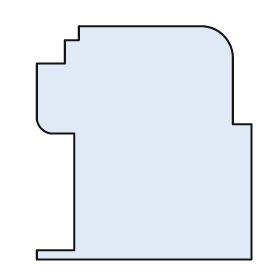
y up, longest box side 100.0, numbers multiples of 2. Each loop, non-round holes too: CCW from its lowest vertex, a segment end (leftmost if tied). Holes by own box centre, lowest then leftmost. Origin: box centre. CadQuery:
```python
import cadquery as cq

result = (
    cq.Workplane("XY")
    .moveTo(-46.0, -50.0)
    .lineTo(46.0, -50.0)
    .lineTo(46.0, 8.0)
    .lineTo(38.0, 8.0)
    .lineTo(38.0, 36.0)
    .threePointArc((34.0, 46.0), (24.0, 50.0))
    .lineTo(-28.0, 50.0)
    .lineTo(-28.0, 44.0)
    .lineTo(-34.0, 44.0)
    .lineTo(-34.0, 34.0)
    .lineTo(-46.0, 34.0)
    .lineTo(-46.0, 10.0)
    .threePointArc((-44.0, 6.0), (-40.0, 4.0))
    .lineTo(-30.0, 4.0)
    .lineTo(-30.0, -46.0)
    .lineTo(-46.0, -46.0)
    .close()
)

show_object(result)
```